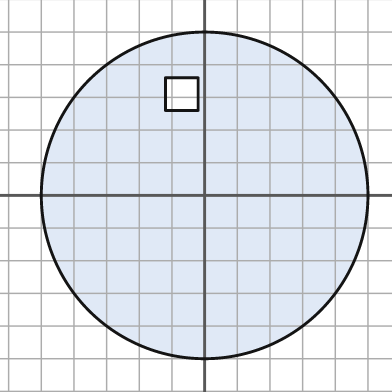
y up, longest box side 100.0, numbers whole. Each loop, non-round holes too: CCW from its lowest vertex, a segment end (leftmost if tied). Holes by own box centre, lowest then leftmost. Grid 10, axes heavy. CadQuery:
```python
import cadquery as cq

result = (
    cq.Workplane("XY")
    .moveTo(0.0, 0.0)
    .circle(50.0)
    .moveTo(-12.0, 26.0)
    .lineTo(-2.0, 26.0)
    .lineTo(-2.0, 36.0)
    .lineTo(-12.0, 36.0)
    .close()
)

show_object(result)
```